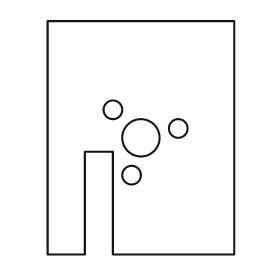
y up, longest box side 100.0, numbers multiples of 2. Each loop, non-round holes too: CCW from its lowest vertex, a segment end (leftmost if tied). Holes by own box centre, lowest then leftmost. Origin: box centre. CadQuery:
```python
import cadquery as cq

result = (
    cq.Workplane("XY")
    .moveTo(-40.0, -50.0)
    .lineTo(-24.0, -50.0)
    .lineTo(-24.0, -6.0)
    .lineTo(-12.0, -6.0)
    .lineTo(-12.0, -50.0)
    .lineTo(40.0, -50.0)
    .lineTo(40.0, 50.0)
    .lineTo(-40.0, 50.0)
    .close()
    .moveTo(-4.0, -16.0)
    .circle(4.0)
    .moveTo(0.0, 0.0)
    .circle(8.0)
    .moveTo(16.0, 4.0)
    .circle(4.0)
    .moveTo(-12.0, 12.0)
    .circle(4.0)
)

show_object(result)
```